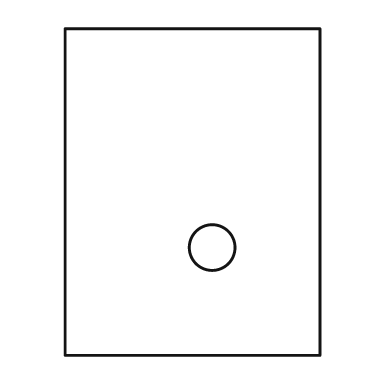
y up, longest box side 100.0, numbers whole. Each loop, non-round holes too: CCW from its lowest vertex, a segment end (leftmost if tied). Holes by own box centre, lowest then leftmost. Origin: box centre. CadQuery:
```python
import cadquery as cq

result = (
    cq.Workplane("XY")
    .moveTo(-39.0, -50.0)
    .lineTo(39.0, -50.0)
    .lineTo(39.0, 50.0)
    .lineTo(-39.0, 50.0)
    .close()
    .moveTo(6.0, -17.0)
    .circle(7.0)
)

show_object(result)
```